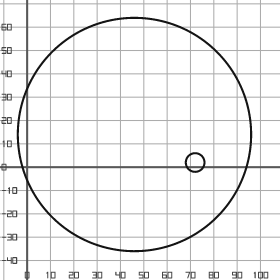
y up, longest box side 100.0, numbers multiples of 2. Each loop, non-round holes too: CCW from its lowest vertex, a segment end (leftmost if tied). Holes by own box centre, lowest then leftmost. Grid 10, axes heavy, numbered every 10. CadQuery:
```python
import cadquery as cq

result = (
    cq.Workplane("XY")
    .moveTo(46.0, 14.0)
    .circle(50.0)
    .moveTo(72.0, 2.0)
    .circle(4.0)
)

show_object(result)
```